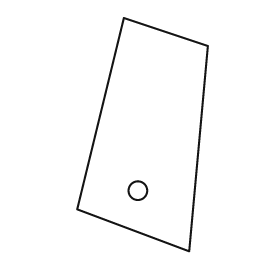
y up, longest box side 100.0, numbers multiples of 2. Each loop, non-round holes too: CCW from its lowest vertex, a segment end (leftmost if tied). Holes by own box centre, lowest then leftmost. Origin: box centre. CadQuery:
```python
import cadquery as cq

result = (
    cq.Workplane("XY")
    .moveTo(20.0, -50.0)
    .lineTo(28.0, 38.0)
    .lineTo(-8.0, 50.0)
    .lineTo(-28.0, -32.0)
    .close()
    .moveTo(-2.0, -24.0)
    .circle(4.0)
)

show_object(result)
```